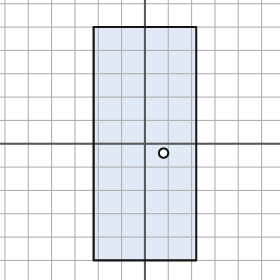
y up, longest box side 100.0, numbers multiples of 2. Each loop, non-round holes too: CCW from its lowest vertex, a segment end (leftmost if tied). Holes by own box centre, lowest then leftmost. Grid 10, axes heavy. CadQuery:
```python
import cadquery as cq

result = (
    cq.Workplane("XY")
    .moveTo(-22.0, -50.0)
    .lineTo(22.0, -50.0)
    .lineTo(22.0, 50.0)
    .lineTo(-22.0, 50.0)
    .close()
    .moveTo(8.0, -4.0)
    .circle(2.0)
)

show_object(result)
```